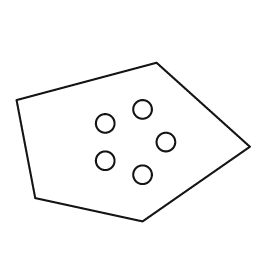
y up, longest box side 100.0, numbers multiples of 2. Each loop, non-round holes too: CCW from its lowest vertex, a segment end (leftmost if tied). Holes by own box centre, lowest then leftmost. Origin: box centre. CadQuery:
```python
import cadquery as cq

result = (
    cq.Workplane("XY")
    .moveTo(4.0, -34.0)
    .lineTo(50.0, -2.0)
    .lineTo(10.0, 34.0)
    .lineTo(-50.0, 18.0)
    .lineTo(-42.0, -24.0)
    .close()
    .moveTo(4.0, -14.0)
    .circle(4.0)
    .moveTo(-12.0, -8.0)
    .circle(4.0)
    .moveTo(14.0, 0.0)
    .circle(4.0)
    .moveTo(-12.0, 8.0)
    .circle(4.0)
    .moveTo(4.0, 14.0)
    .circle(4.0)
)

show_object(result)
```